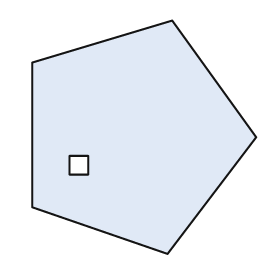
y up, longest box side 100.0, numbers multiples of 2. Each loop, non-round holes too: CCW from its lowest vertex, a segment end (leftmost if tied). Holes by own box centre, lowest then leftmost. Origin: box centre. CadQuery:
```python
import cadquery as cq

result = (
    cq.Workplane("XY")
    .moveTo(10.0, -50.0)
    .lineTo(48.0, 0.0)
    .lineTo(12.0, 50.0)
    .lineTo(-48.0, 32.0)
    .lineTo(-48.0, -30.0)
    .close()
    .moveTo(-32.0, -16.0)
    .lineTo(-24.0, -16.0)
    .lineTo(-24.0, -8.0)
    .lineTo(-32.0, -8.0)
    .close()
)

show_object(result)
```